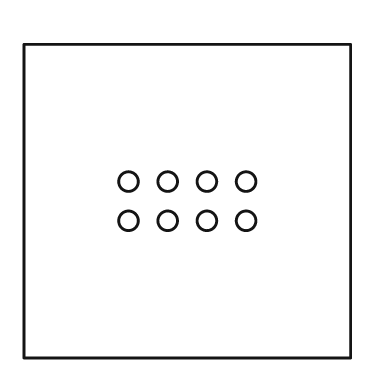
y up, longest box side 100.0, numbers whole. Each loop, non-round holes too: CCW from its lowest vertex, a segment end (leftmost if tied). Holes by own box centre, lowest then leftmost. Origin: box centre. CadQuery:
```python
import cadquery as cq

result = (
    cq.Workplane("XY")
    .moveTo(-50.0, -48.0)
    .lineTo(50.0, -48.0)
    .lineTo(50.0, 48.0)
    .lineTo(-50.0, 48.0)
    .close()
    .moveTo(-18.0, -6.0)
    .circle(3.0)
    .moveTo(-6.0, -6.0)
    .circle(3.0)
    .moveTo(6.0, -6.0)
    .circle(3.0)
    .moveTo(18.0, -6.0)
    .circle(3.0)
    .moveTo(-18.0, 6.0)
    .circle(3.0)
    .moveTo(-6.0, 6.0)
    .circle(3.0)
    .moveTo(6.0, 6.0)
    .circle(3.0)
    .moveTo(18.0, 6.0)
    .circle(3.0)
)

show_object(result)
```